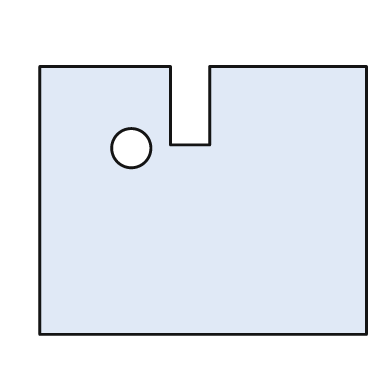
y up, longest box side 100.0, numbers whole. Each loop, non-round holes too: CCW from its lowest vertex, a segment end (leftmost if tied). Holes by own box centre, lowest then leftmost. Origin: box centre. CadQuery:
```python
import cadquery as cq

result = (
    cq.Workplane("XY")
    .moveTo(-50.0, -41.0)
    .lineTo(50.0, -41.0)
    .lineTo(50.0, 41.0)
    .lineTo(2.0, 41.0)
    .lineTo(2.0, 17.0)
    .lineTo(-10.0, 17.0)
    .lineTo(-10.0, 41.0)
    .lineTo(-50.0, 41.0)
    .close()
    .moveTo(-22.0, 16.0)
    .circle(6.0)
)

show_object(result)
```